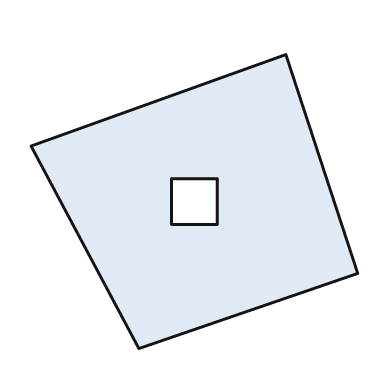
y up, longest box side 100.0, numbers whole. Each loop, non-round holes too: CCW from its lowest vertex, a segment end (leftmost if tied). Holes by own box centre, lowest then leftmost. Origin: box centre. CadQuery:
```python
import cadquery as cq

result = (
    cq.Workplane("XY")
    .moveTo(-17.0, -45.0)
    .lineTo(50.0, -22.0)
    .lineTo(28.0, 45.0)
    .lineTo(-50.0, 17.0)
    .close()
    .moveTo(-7.0, -7.0)
    .lineTo(7.0, -7.0)
    .lineTo(7.0, 7.0)
    .lineTo(-7.0, 7.0)
    .close()
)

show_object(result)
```